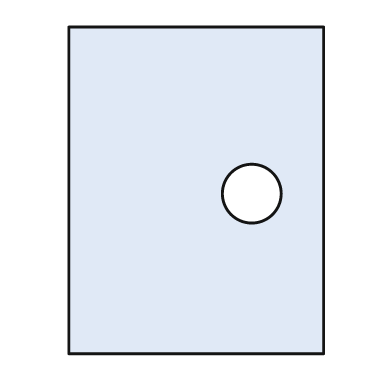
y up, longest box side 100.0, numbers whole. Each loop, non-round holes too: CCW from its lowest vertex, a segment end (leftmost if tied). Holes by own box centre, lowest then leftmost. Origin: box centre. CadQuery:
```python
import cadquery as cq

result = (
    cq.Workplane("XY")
    .moveTo(-39.0, -50.0)
    .lineTo(39.0, -50.0)
    .lineTo(39.0, 50.0)
    .lineTo(-39.0, 50.0)
    .close()
    .moveTo(17.0, -1.0)
    .circle(9.0)
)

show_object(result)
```